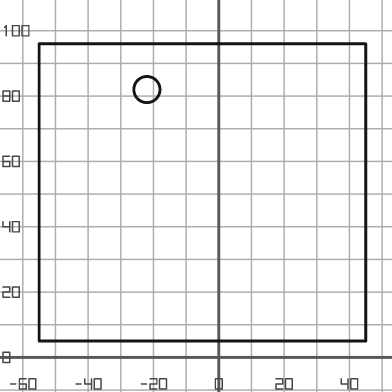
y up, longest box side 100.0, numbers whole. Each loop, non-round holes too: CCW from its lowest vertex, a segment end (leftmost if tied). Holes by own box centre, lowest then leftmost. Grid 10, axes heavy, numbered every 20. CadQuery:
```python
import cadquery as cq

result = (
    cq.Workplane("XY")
    .moveTo(-55.0, 5.0)
    .lineTo(45.0, 5.0)
    .lineTo(45.0, 96.0)
    .lineTo(-55.0, 96.0)
    .close()
    .moveTo(-22.0, 82.0)
    .circle(4.0)
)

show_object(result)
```